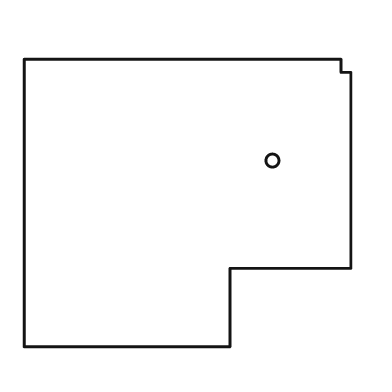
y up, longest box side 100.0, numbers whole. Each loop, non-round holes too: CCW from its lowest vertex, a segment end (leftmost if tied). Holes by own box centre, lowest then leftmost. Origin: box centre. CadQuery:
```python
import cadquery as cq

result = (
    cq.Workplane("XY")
    .moveTo(-50.0, -44.0)
    .lineTo(13.0, -44.0)
    .lineTo(13.0, -20.0)
    .lineTo(50.0, -20.0)
    .lineTo(50.0, 40.0)
    .lineTo(47.0, 40.0)
    .lineTo(47.0, 44.0)
    .lineTo(-50.0, 44.0)
    .close()
    .moveTo(26.0, 13.0)
    .circle(2.0)
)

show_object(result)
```